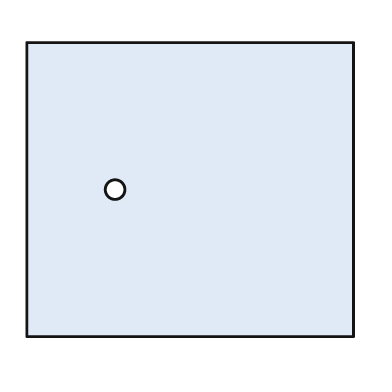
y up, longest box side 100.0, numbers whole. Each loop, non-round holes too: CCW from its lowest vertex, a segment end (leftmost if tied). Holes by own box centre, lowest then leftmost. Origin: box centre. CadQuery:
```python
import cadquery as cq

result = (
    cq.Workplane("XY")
    .moveTo(-50.0, -45.0)
    .lineTo(50.0, -45.0)
    .lineTo(50.0, 45.0)
    .lineTo(-50.0, 45.0)
    .close()
    .moveTo(-23.0, 0.0)
    .circle(3.0)
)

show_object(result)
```